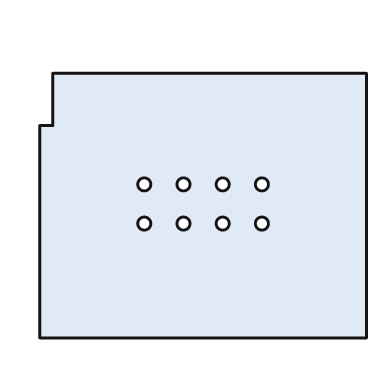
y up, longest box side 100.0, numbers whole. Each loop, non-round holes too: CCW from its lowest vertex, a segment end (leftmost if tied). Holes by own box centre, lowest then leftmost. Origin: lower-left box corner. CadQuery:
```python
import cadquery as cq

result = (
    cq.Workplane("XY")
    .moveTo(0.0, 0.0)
    .lineTo(100.0, 0.0)
    .lineTo(100.0, 81.0)
    .lineTo(4.0, 81.0)
    .lineTo(4.0, 65.0)
    .lineTo(0.0, 65.0)
    .close()
    .moveTo(32.0, 35.0)
    .circle(2.0)
    .moveTo(44.0, 35.0)
    .circle(2.0)
    .moveTo(56.0, 35.0)
    .circle(2.0)
    .moveTo(68.0, 35.0)
    .circle(2.0)
    .moveTo(32.0, 47.0)
    .circle(2.0)
    .moveTo(44.0, 47.0)
    .circle(2.0)
    .moveTo(56.0, 47.0)
    .circle(2.0)
    .moveTo(68.0, 47.0)
    .circle(2.0)
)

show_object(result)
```